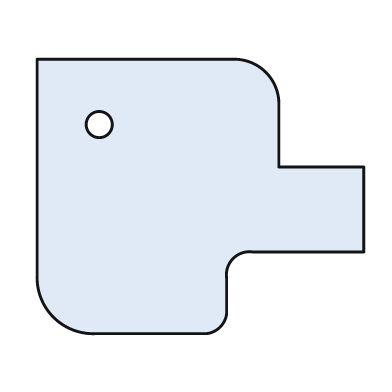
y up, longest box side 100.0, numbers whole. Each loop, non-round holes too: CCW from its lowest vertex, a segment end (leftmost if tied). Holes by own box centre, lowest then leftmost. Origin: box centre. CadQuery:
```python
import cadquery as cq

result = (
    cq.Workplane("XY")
    .moveTo(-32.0, -42.0)
    .lineTo(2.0, -42.0)
    .threePointArc((6.0, -40.0), (8.0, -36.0))
    .lineTo(8.0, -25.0)
    .threePointArc((10.0, -19.0), (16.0, -17.0))
    .lineTo(50.0, -17.0)
    .lineTo(50.0, 9.0)
    .lineTo(24.0, 9.0)
    .lineTo(24.0, 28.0)
    .threePointArc((20.0, 38.0), (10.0, 42.0))
    .lineTo(-50.0, 42.0)
    .lineTo(-50.0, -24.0)
    .threePointArc((-45.0, -37.0), (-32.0, -42.0))
    .close()
    .moveTo(-31.0, 22.0)
    .circle(4.0)
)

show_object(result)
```